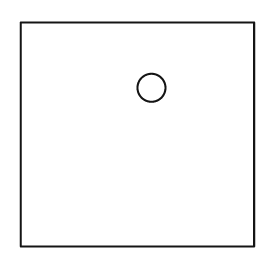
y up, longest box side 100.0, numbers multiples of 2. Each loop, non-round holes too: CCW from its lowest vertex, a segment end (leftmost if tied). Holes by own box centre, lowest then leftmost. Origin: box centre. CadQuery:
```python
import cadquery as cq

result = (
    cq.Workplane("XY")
    .moveTo(-50.0, -48.0)
    .lineTo(50.0, -48.0)
    .lineTo(50.0, 48.0)
    .lineTo(-50.0, 48.0)
    .close()
    .moveTo(6.0, 20.0)
    .circle(6.0)
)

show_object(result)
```